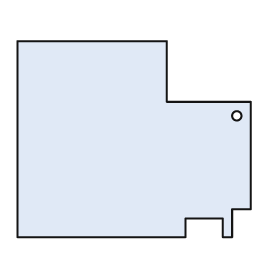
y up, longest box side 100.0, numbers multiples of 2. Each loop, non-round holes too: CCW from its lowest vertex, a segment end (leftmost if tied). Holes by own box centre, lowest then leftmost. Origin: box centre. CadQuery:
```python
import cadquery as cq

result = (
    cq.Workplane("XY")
    .moveTo(-50.0, -42.0)
    .lineTo(22.0, -42.0)
    .lineTo(22.0, -34.0)
    .lineTo(38.0, -34.0)
    .lineTo(38.0, -42.0)
    .lineTo(42.0, -42.0)
    .lineTo(42.0, -30.0)
    .lineTo(50.0, -30.0)
    .lineTo(50.0, 16.0)
    .lineTo(14.0, 16.0)
    .lineTo(14.0, 42.0)
    .lineTo(-50.0, 42.0)
    .close()
    .moveTo(44.0, 10.0)
    .circle(2.0)
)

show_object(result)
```